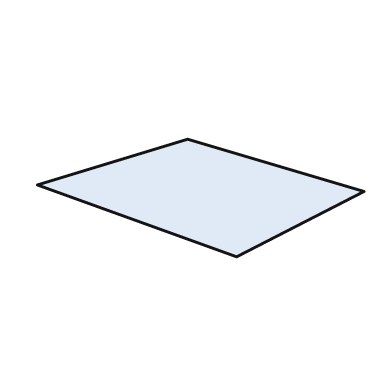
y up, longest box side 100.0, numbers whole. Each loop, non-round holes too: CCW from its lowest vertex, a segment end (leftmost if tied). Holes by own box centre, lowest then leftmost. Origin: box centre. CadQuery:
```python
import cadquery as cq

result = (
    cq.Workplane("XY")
    .moveTo(11.0, -18.0)
    .lineTo(50.0, 2.0)
    .lineTo(-4.0, 18.0)
    .lineTo(-50.0, 4.0)
    .close()
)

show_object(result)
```